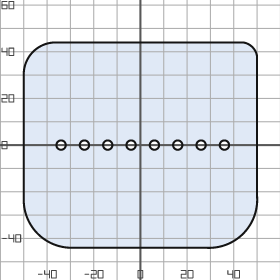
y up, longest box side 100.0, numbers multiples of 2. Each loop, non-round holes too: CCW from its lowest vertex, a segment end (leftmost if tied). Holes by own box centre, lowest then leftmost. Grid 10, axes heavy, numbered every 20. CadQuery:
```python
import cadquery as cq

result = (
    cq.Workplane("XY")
    .moveTo(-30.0, -44.0)
    .lineTo(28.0, -44.0)
    .threePointArc((44.0, -38.0), (50.0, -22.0))
    .lineTo(50.0, 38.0)
    .threePointArc((48.0, 42.0), (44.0, 44.0))
    .lineTo(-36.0, 44.0)
    .threePointArc((-46.0, 40.0), (-50.0, 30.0))
    .lineTo(-50.0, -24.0)
    .threePointArc((-44.0, -38.0), (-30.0, -44.0))
    .close()
    .moveTo(-34.0, 0.0)
    .circle(2.0)
    .moveTo(-24.0, 0.0)
    .circle(2.0)
    .moveTo(-14.0, 0.0)
    .circle(2.0)
    .moveTo(-4.0, 0.0)
    .circle(2.0)
    .moveTo(6.0, 0.0)
    .circle(2.0)
    .moveTo(16.0, 0.0)
    .circle(2.0)
    .moveTo(26.0, 0.0)
    .circle(2.0)
    .moveTo(36.0, 0.0)
    .circle(2.0)
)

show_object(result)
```